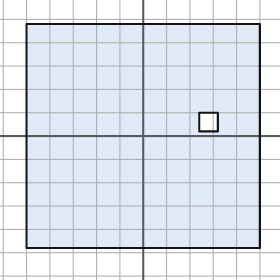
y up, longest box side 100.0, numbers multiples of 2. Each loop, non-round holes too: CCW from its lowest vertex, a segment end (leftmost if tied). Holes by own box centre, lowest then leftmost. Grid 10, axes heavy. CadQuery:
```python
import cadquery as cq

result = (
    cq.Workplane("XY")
    .moveTo(-50.0, -48.0)
    .lineTo(50.0, -48.0)
    .lineTo(50.0, 48.0)
    .lineTo(-50.0, 48.0)
    .close()
    .moveTo(24.0, 2.0)
    .lineTo(32.0, 2.0)
    .lineTo(32.0, 10.0)
    .lineTo(24.0, 10.0)
    .close()
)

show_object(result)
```